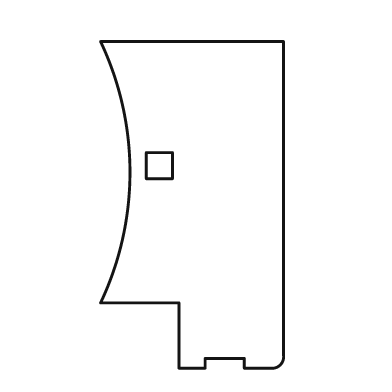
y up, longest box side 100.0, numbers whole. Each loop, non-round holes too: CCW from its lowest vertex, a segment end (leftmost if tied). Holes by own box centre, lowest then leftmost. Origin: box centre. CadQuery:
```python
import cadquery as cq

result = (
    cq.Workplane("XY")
    .moveTo(-4.0, -50.0)
    .lineTo(4.0, -50.0)
    .lineTo(4.0, -47.0)
    .lineTo(16.0, -47.0)
    .lineTo(16.0, -50.0)
    .lineTo(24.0, -50.0)
    .threePointArc((27.0, -49.0), (28.0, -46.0))
    .lineTo(28.0, 50.0)
    .lineTo(-28.0, 50.0)
    .threePointArc((-19.0, 10.0), (-28.0, -30.0))
    .lineTo(-4.0, -30.0)
    .close()
    .moveTo(-14.0, 8.0)
    .lineTo(-6.0, 8.0)
    .lineTo(-6.0, 16.0)
    .lineTo(-14.0, 16.0)
    .close()
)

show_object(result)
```